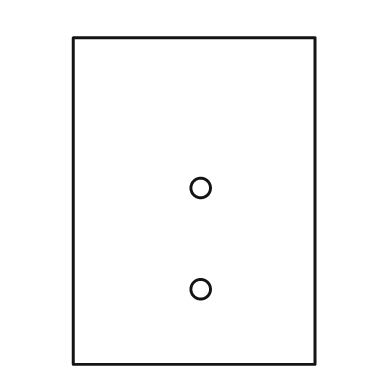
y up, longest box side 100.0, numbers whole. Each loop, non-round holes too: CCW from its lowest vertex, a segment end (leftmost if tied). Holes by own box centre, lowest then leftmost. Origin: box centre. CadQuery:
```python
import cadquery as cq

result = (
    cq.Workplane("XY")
    .moveTo(-37.0, -50.0)
    .lineTo(37.0, -50.0)
    .lineTo(37.0, 50.0)
    .lineTo(-37.0, 50.0)
    .close()
    .moveTo(2.0, -27.0)
    .circle(3.0)
    .moveTo(2.0, 4.0)
    .circle(3.0)
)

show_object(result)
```